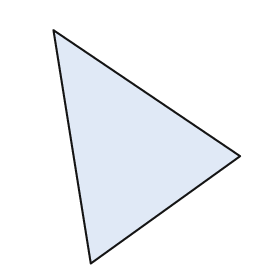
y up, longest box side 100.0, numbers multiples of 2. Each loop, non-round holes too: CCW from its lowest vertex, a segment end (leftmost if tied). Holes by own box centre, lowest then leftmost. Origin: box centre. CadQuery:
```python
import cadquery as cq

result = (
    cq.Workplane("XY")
    .moveTo(-24.0, -50.0)
    .lineTo(40.0, -4.0)
    .lineTo(-40.0, 50.0)
    .close()
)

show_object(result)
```